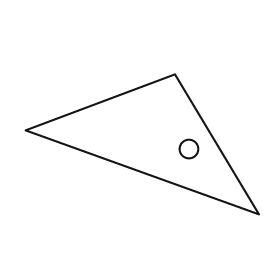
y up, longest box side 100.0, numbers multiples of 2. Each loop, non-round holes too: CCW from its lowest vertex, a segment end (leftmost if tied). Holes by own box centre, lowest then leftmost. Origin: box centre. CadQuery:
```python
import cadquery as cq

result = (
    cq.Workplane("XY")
    .moveTo(50.0, -30.0)
    .lineTo(14.0, 30.0)
    .lineTo(-50.0, 6.0)
    .close()
    .moveTo(20.0, -2.0)
    .circle(4.0)
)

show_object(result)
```